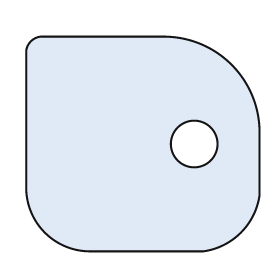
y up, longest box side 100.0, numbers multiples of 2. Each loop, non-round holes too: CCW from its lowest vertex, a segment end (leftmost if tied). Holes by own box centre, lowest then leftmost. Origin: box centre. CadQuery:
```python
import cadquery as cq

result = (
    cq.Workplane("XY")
    .moveTo(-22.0, -46.0)
    .lineTo(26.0, -46.0)
    .threePointArc((42.0, -38.0), (50.0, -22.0))
    .lineTo(50.0, 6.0)
    .threePointArc((38.0, 34.0), (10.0, 46.0))
    .lineTo(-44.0, 46.0)
    .threePointArc((-48.0, 44.0), (-50.0, 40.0))
    .lineTo(-50.0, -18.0)
    .threePointArc((-42.0, -38.0), (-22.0, -46.0))
    .close()
    .moveTo(22.0, 0.0)
    .circle(10.0)
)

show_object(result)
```